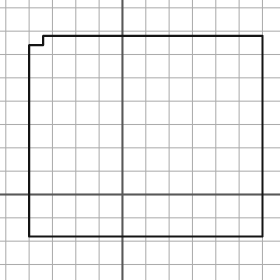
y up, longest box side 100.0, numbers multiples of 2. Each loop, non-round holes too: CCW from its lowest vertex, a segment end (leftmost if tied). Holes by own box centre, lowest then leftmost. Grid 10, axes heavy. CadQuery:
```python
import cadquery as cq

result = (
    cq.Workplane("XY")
    .moveTo(-40.0, -18.0)
    .lineTo(60.0, -18.0)
    .lineTo(60.0, 68.0)
    .lineTo(-34.0, 68.0)
    .lineTo(-34.0, 64.0)
    .lineTo(-40.0, 64.0)
    .close()
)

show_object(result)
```